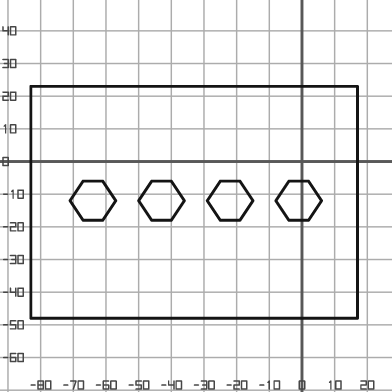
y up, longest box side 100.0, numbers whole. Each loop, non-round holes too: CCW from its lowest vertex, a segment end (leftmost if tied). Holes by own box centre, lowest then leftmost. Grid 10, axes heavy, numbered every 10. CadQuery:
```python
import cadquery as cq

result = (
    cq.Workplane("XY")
    .moveTo(-83.0, -48.0)
    .lineTo(17.0, -48.0)
    .lineTo(17.0, 23.0)
    .lineTo(-83.0, 23.0)
    .close()
    .moveTo(-67.0, -18.0)
    .lineTo(-61.0, -18.0)
    .lineTo(-57.0, -12.0)
    .lineTo(-61.0, -6.0)
    .lineTo(-67.0, -6.0)
    .lineTo(-71.0, -12.0)
    .close()
    .moveTo(-46.0, -18.0)
    .lineTo(-40.0, -18.0)
    .lineTo(-36.0, -12.0)
    .lineTo(-40.0, -6.0)
    .lineTo(-46.0, -6.0)
    .lineTo(-50.0, -12.0)
    .close()
    .moveTo(-25.0, -18.0)
    .lineTo(-19.0, -18.0)
    .lineTo(-15.0, -12.0)
    .lineTo(-19.0, -6.0)
    .lineTo(-25.0, -6.0)
    .lineTo(-29.0, -12.0)
    .close()
    .moveTo(-4.0, -18.0)
    .lineTo(2.0, -18.0)
    .lineTo(6.0, -12.0)
    .lineTo(2.0, -6.0)
    .lineTo(-4.0, -6.0)
    .lineTo(-8.0, -12.0)
    .close()
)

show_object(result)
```